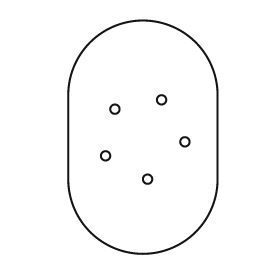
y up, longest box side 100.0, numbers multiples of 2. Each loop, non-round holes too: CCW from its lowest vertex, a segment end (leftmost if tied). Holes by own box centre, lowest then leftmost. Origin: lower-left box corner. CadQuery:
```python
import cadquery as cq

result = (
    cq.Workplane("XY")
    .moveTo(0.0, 32.0)
    .threePointArc((32.0, 0.0), (64.0, 32.0))
    .lineTo(64.0, 68.0)
    .threePointArc((32.0, 100.0), (0.0, 68.0))
    .close()
    .moveTo(34.0, 32.0)
    .circle(2.0)
    .moveTo(16.0, 42.0)
    .circle(2.0)
    .moveTo(50.0, 48.0)
    .circle(2.0)
    .moveTo(20.0, 62.0)
    .circle(2.0)
    .moveTo(40.0, 66.0)
    .circle(2.0)
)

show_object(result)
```